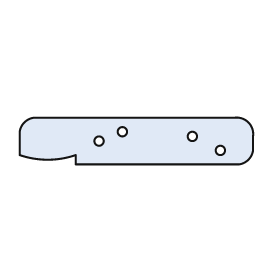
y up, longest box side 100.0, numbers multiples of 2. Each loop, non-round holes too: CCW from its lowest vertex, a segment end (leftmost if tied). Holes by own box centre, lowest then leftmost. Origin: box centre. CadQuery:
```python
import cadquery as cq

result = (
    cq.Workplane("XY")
    .moveTo(-26.0, -10.0)
    .lineTo(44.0, -10.0)
    .threePointArc((48.0, -8.0), (50.0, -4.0))
    .lineTo(50.0, 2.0)
    .threePointArc((48.0, 8.0), (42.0, 10.0))
    .lineTo(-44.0, 10.0)
    .threePointArc((-48.0, 8.0), (-50.0, 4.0))
    .lineTo(-50.0, -6.0)
    .threePointArc((-38.0, -8.0), (-26.0, -6.0))
    .close()
    .moveTo(36.0, -4.0)
    .circle(2.0)
    .moveTo(-16.0, 0.0)
    .circle(2.0)
    .moveTo(24.0, 2.0)
    .circle(2.0)
    .moveTo(-6.0, 4.0)
    .circle(2.0)
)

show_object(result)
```